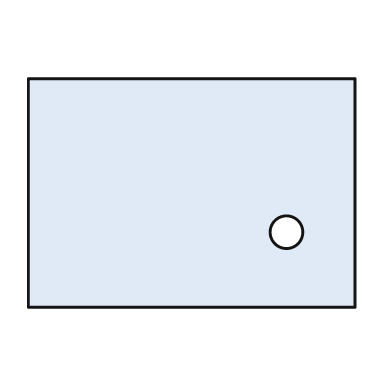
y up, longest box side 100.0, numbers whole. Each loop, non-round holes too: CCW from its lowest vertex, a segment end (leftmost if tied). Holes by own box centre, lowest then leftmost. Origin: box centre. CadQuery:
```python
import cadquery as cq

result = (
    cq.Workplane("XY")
    .moveTo(-50.0, -35.0)
    .lineTo(50.0, -35.0)
    .lineTo(50.0, 35.0)
    .lineTo(-50.0, 35.0)
    .close()
    .moveTo(29.0, -12.0)
    .circle(5.0)
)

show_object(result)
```